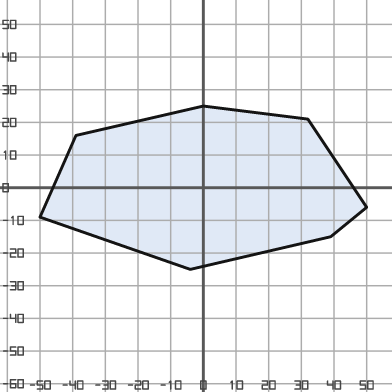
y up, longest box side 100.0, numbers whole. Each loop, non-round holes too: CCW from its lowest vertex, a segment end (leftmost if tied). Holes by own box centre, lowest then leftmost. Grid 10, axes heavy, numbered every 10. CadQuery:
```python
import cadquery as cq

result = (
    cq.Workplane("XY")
    .moveTo(-4.0, -25.0)
    .lineTo(39.0, -15.0)
    .lineTo(50.0, -6.0)
    .lineTo(32.0, 21.0)
    .lineTo(0.0, 25.0)
    .lineTo(-39.0, 16.0)
    .lineTo(-50.0, -9.0)
    .close()
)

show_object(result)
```